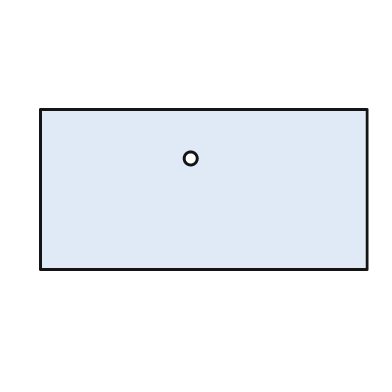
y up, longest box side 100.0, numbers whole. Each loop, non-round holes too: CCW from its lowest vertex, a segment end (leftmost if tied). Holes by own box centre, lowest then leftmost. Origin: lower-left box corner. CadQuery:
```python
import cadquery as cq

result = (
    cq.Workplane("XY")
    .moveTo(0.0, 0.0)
    .lineTo(100.0, 0.0)
    .lineTo(100.0, 49.0)
    .lineTo(0.0, 49.0)
    .close()
    .moveTo(46.0, 34.0)
    .circle(2.0)
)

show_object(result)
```